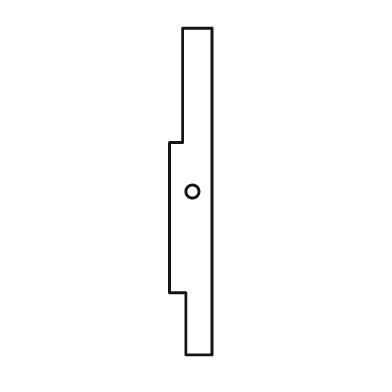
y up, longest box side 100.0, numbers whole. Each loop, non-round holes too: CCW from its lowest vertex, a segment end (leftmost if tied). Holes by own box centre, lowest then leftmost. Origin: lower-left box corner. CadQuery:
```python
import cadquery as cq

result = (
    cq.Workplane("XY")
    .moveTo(5.0, 0.0)
    .lineTo(13.0, 0.0)
    .lineTo(13.0, 100.0)
    .lineTo(4.0, 100.0)
    .lineTo(4.0, 65.0)
    .lineTo(0.0, 65.0)
    .lineTo(0.0, 19.0)
    .lineTo(5.0, 19.0)
    .close()
    .moveTo(7.0, 50.0)
    .circle(2.0)
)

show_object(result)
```